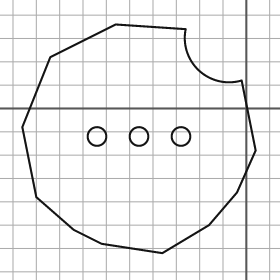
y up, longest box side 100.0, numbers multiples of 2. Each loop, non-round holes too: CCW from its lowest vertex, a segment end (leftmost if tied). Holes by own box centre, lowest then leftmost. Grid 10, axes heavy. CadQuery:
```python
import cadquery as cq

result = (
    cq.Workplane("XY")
    .moveTo(-36.0, -62.0)
    .lineTo(-16.0, -50.0)
    .lineTo(-4.0, -36.0)
    .lineTo(4.0, -18.0)
    .lineTo(-2.0, 12.0)
    .threePointArc((-20.0, 16.0), (-26.0, 34.0))
    .lineTo(-56.0, 36.0)
    .lineTo(-84.0, 22.0)
    .lineTo(-96.0, -8.0)
    .lineTo(-90.0, -38.0)
    .lineTo(-74.0, -52.0)
    .lineTo(-62.0, -58.0)
    .close()
    .moveTo(-64.0, -12.0)
    .circle(4.0)
    .moveTo(-46.0, -12.0)
    .circle(4.0)
    .moveTo(-28.0, -12.0)
    .circle(4.0)
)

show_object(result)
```